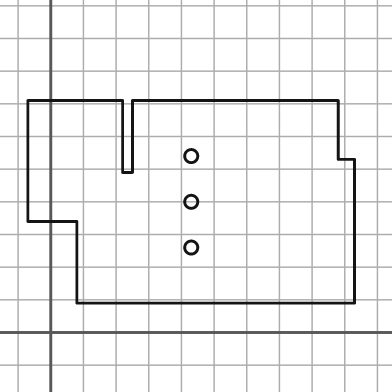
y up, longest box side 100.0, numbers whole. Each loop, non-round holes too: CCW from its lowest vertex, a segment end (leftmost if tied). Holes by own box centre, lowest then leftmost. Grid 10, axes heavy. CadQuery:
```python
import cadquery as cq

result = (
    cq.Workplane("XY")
    .moveTo(8.0, 9.0)
    .lineTo(93.0, 9.0)
    .lineTo(93.0, 53.0)
    .lineTo(88.0, 53.0)
    .lineTo(88.0, 71.0)
    .lineTo(25.0, 71.0)
    .lineTo(25.0, 49.0)
    .lineTo(22.0, 49.0)
    .lineTo(22.0, 71.0)
    .lineTo(-7.0, 71.0)
    .lineTo(-7.0, 34.0)
    .lineTo(8.0, 34.0)
    .close()
    .moveTo(43.0, 26.0)
    .circle(2.0)
    .moveTo(43.0, 40.0)
    .circle(2.0)
    .moveTo(43.0, 54.0)
    .circle(2.0)
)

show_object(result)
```